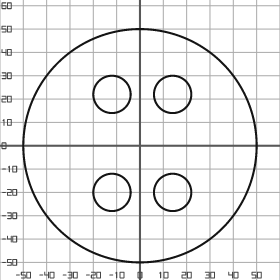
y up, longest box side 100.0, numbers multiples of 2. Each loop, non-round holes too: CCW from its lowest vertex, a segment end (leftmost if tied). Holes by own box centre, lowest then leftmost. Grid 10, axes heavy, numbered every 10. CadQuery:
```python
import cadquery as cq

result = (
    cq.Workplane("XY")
    .moveTo(0.0, 0.0)
    .circle(50.0)
    .moveTo(-12.0, -20.0)
    .circle(8.0)
    .moveTo(14.0, -20.0)
    .circle(8.0)
    .moveTo(-12.0, 22.0)
    .circle(8.0)
    .moveTo(14.0, 22.0)
    .circle(8.0)
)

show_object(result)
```